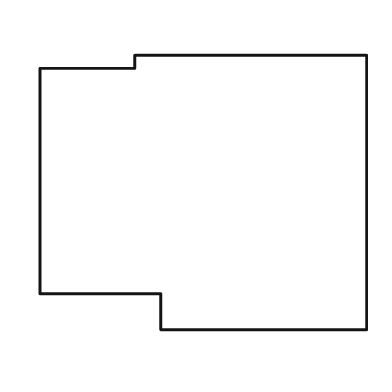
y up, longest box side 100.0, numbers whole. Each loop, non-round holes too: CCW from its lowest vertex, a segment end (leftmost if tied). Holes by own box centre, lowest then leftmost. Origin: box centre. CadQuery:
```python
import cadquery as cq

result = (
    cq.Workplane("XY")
    .moveTo(-13.0, -42.0)
    .lineTo(50.0, -42.0)
    .lineTo(50.0, 42.0)
    .lineTo(-21.0, 42.0)
    .lineTo(-21.0, 38.0)
    .lineTo(-50.0, 38.0)
    .lineTo(-50.0, -31.0)
    .lineTo(-13.0, -31.0)
    .close()
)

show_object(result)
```